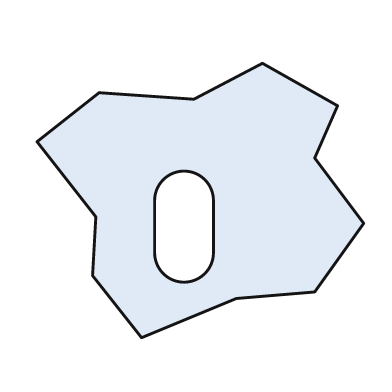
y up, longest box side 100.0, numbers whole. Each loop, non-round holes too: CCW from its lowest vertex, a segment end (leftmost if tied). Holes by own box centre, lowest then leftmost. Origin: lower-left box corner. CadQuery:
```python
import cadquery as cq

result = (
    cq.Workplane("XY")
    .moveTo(32.0, 0.0)
    .lineTo(61.0, 12.0)
    .lineTo(85.0, 14.0)
    .lineTo(100.0, 35.0)
    .lineTo(85.0, 55.0)
    .lineTo(92.0, 71.0)
    .lineTo(69.0, 84.0)
    .lineTo(48.0, 73.0)
    .lineTo(19.0, 75.0)
    .lineTo(0.0, 60.0)
    .lineTo(18.0, 37.0)
    .lineTo(17.0, 19.0)
    .close()
    .moveTo(36.0, 26.0)
    .threePointArc((45.0, 17.0), (54.0, 26.0))
    .lineTo(54.0, 42.0)
    .threePointArc((45.0, 51.0), (36.0, 42.0))
    .close()
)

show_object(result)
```